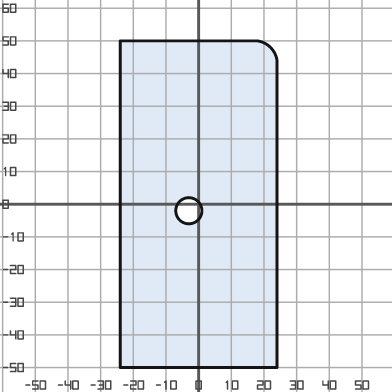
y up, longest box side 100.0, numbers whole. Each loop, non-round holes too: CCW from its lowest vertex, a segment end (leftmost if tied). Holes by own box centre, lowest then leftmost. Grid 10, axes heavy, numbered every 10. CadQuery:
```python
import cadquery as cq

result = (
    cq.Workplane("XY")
    .moveTo(-24.0, -50.0)
    .lineTo(24.0, -50.0)
    .lineTo(24.0, 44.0)
    .threePointArc((22.0, 48.0), (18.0, 50.0))
    .lineTo(-24.0, 50.0)
    .close()
    .moveTo(-3.0, -2.0)
    .circle(4.0)
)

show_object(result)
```